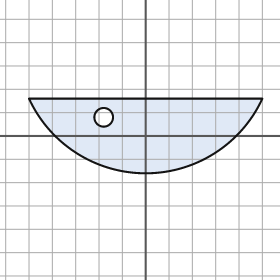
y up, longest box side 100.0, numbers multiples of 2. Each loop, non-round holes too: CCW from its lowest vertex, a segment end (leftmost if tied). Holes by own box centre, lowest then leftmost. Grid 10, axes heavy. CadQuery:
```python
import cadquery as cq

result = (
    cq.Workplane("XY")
    .moveTo(-50.0, 16.0)
    .threePointArc((0.0, -16.0), (50.0, 16.0))
    .close()
    .moveTo(-18.0, 8.0)
    .circle(4.0)
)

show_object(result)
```